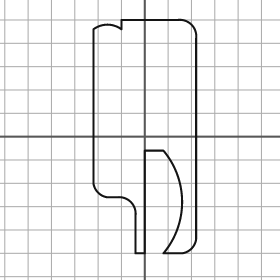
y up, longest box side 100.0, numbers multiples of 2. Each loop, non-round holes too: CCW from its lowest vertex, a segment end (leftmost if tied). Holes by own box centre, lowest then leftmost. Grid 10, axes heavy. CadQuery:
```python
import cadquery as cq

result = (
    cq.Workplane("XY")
    .moveTo(-4.0, -50.0)
    .lineTo(0.0, -50.0)
    .lineTo(0.0, -6.0)
    .lineTo(8.0, -6.0)
    .threePointArc((16.0, -28.0), (8.0, -50.0))
    .lineTo(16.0, -50.0)
    .threePointArc((20.0, -48.0), (22.0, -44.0))
    .lineTo(22.0, 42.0)
    .threePointArc((20.0, 48.0), (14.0, 50.0))
    .lineTo(-10.0, 50.0)
    .lineTo(-10.0, 46.0)
    .threePointArc((-16.0, 48.0), (-22.0, 46.0))
    .lineTo(-22.0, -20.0)
    .threePointArc((-20.0, -24.0), (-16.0, -26.0))
    .lineTo(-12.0, -26.0)
    .threePointArc((-6.0, -28.0), (-4.0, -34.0))
    .close()
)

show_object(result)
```